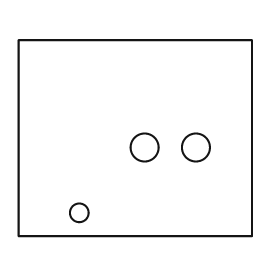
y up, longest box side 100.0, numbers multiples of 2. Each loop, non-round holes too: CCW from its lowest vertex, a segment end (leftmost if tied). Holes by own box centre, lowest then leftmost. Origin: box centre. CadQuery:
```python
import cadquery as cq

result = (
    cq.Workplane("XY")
    .moveTo(-50.0, -42.0)
    .lineTo(50.0, -42.0)
    .lineTo(50.0, 42.0)
    .lineTo(-50.0, 42.0)
    .close()
    .moveTo(-24.0, -32.0)
    .circle(4.0)
    .moveTo(4.0, -4.0)
    .circle(6.0)
    .moveTo(26.0, -4.0)
    .circle(6.0)
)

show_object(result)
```